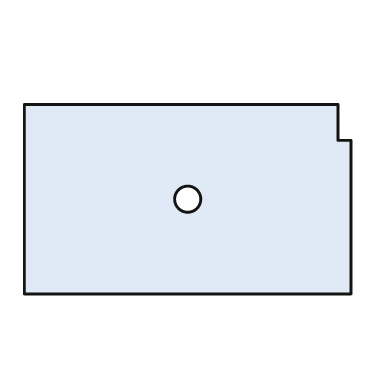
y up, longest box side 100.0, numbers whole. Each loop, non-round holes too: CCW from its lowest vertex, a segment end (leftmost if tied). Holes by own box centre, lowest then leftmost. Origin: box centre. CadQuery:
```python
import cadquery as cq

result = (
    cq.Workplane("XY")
    .moveTo(-50.0, -29.0)
    .lineTo(50.0, -29.0)
    .lineTo(50.0, 18.0)
    .lineTo(46.0, 18.0)
    .lineTo(46.0, 29.0)
    .lineTo(-50.0, 29.0)
    .close()
    .moveTo(0.0, 0.0)
    .circle(4.0)
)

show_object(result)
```